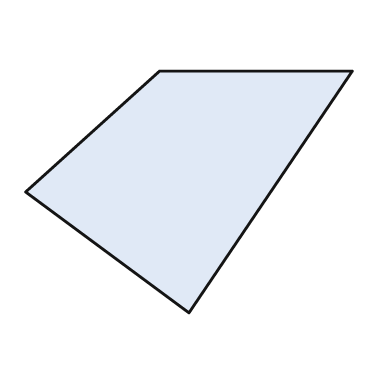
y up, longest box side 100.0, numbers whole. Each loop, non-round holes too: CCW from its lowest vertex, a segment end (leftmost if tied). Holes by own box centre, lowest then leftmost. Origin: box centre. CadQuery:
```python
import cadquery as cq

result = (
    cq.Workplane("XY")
    .moveTo(0.0, -37.0)
    .lineTo(50.0, 37.0)
    .lineTo(-9.0, 37.0)
    .lineTo(-50.0, 0.0)
    .close()
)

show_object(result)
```